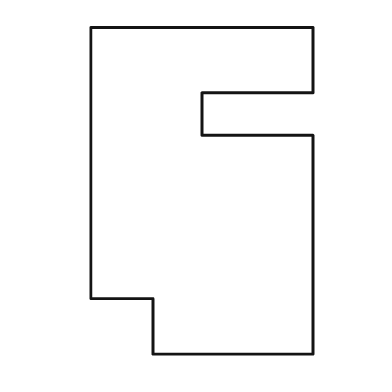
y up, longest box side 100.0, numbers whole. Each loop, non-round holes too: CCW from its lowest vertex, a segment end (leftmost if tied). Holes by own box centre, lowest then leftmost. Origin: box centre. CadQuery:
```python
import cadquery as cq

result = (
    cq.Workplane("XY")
    .moveTo(-15.0, -50.0)
    .lineTo(34.0, -50.0)
    .lineTo(34.0, 17.0)
    .lineTo(0.0, 17.0)
    .lineTo(0.0, 30.0)
    .lineTo(34.0, 30.0)
    .lineTo(34.0, 50.0)
    .lineTo(-34.0, 50.0)
    .lineTo(-34.0, -33.0)
    .lineTo(-15.0, -33.0)
    .close()
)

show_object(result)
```